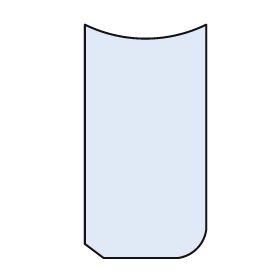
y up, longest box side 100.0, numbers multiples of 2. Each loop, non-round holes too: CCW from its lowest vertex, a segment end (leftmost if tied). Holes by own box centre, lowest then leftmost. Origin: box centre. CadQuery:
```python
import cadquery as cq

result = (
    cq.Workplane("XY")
    .moveTo(-18.0, -50.0)
    .lineTo(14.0, -50.0)
    .threePointArc((22.0, -46.0), (26.0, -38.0))
    .lineTo(26.0, 50.0)
    .threePointArc((0.0, 44.0), (-26.0, 50.0))
    .lineTo(-26.0, -44.0)
    .close()
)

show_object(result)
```